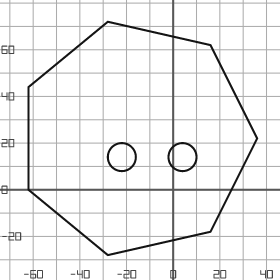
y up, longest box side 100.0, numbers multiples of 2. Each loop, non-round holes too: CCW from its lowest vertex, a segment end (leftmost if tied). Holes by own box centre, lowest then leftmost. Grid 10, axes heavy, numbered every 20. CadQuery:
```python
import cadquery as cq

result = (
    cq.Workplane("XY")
    .moveTo(-28.0, -28.0)
    .lineTo(16.0, -18.0)
    .lineTo(36.0, 22.0)
    .lineTo(16.0, 62.0)
    .lineTo(-28.0, 72.0)
    .lineTo(-62.0, 44.0)
    .lineTo(-62.0, 0.0)
    .close()
    .moveTo(-22.0, 14.0)
    .circle(6.0)
    .moveTo(4.0, 14.0)
    .circle(6.0)
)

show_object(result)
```